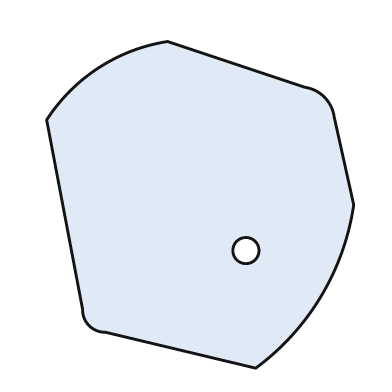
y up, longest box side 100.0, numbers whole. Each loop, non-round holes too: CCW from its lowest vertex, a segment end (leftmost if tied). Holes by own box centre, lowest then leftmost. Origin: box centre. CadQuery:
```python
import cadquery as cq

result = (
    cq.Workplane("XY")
    .moveTo(17.0, -50.0)
    .threePointArc((37.0, -28.0), (47.0, 0.0))
    .lineTo(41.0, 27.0)
    .threePointArc((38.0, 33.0), (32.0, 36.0))
    .lineTo(-10.0, 50.0)
    .threePointArc((-31.0, 42.0), (-47.0, 26.0))
    .lineTo(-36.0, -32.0)
    .threePointArc((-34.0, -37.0), (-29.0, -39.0))
    .close()
    .moveTo(14.0, -14.0)
    .circle(4.0)
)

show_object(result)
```